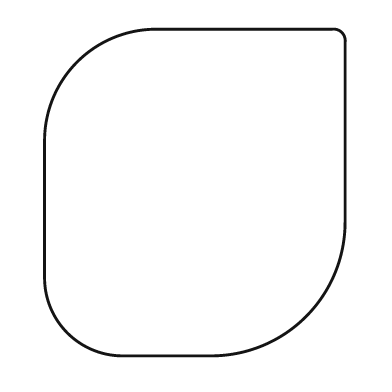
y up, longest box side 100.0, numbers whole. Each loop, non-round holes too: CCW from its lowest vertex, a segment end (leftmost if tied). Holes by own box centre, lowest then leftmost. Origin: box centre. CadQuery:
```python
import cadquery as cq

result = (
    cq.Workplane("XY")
    .moveTo(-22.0, -50.0)
    .lineTo(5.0, -50.0)
    .threePointArc((34.0, -38.0), (46.0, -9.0))
    .lineTo(46.0, 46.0)
    .threePointArc((45.0, 49.0), (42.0, 50.0))
    .lineTo(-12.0, 50.0)
    .threePointArc((-36.0, 40.0), (-46.0, 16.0))
    .lineTo(-46.0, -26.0)
    .threePointArc((-39.0, -43.0), (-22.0, -50.0))
    .close()
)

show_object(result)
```